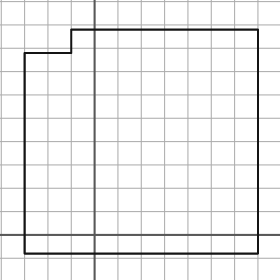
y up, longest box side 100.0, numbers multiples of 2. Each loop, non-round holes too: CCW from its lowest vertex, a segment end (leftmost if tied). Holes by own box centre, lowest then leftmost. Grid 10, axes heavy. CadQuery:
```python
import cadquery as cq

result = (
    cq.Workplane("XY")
    .moveTo(-30.0, -8.0)
    .lineTo(70.0, -8.0)
    .lineTo(70.0, 88.0)
    .lineTo(-10.0, 88.0)
    .lineTo(-10.0, 78.0)
    .lineTo(-30.0, 78.0)
    .close()
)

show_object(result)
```